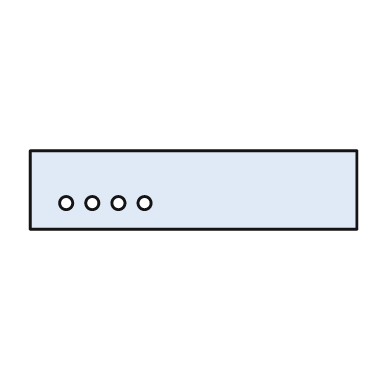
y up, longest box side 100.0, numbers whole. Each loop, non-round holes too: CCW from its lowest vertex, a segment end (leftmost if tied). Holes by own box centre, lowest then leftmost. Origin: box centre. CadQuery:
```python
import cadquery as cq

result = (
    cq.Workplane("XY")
    .moveTo(-50.0, -12.0)
    .lineTo(50.0, -12.0)
    .lineTo(50.0, 12.0)
    .lineTo(-50.0, 12.0)
    .close()
    .moveTo(-39.0, -4.0)
    .circle(2.0)
    .moveTo(-31.0, -4.0)
    .circle(2.0)
    .moveTo(-23.0, -4.0)
    .circle(2.0)
    .moveTo(-15.0, -4.0)
    .circle(2.0)
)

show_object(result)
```